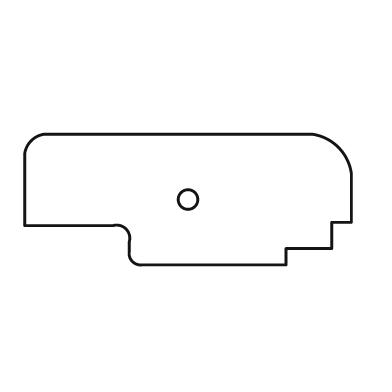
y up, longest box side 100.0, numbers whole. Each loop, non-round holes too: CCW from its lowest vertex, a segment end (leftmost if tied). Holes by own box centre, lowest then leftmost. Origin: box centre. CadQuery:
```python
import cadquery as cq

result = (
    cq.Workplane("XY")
    .moveTo(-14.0, -20.0)
    .lineTo(30.0, -20.0)
    .lineTo(30.0, -15.0)
    .lineTo(44.0, -15.0)
    .lineTo(44.0, -7.0)
    .lineTo(50.0, -7.0)
    .lineTo(50.0, 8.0)
    .threePointArc((46.0, 16.0), (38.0, 20.0))
    .lineTo(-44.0, 20.0)
    .threePointArc((-48.0, 18.0), (-50.0, 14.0))
    .lineTo(-50.0, -8.0)
    .lineTo(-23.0, -8.0)
    .threePointArc((-19.0, -9.0), (-18.0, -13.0))
    .lineTo(-18.0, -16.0)
    .threePointArc((-17.0, -19.0), (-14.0, -20.0))
    .close()
    .moveTo(0.0, 0.0)
    .circle(3.0)
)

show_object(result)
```